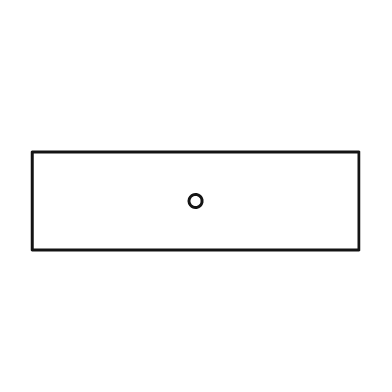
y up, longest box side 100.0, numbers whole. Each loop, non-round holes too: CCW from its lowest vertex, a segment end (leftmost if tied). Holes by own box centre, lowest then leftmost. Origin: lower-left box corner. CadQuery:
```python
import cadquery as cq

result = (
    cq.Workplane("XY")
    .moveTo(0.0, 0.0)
    .lineTo(100.0, 0.0)
    .lineTo(100.0, 30.0)
    .lineTo(0.0, 30.0)
    .close()
    .moveTo(50.0, 15.0)
    .circle(2.0)
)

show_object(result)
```